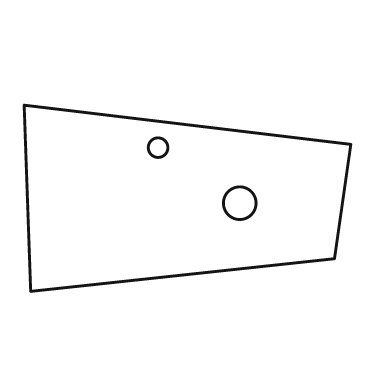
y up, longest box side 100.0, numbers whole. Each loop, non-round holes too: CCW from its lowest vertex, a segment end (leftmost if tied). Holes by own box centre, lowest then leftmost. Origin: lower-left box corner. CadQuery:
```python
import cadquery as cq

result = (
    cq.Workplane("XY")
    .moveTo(2.0, 0.0)
    .lineTo(95.0, 10.0)
    .lineTo(100.0, 45.0)
    .lineTo(0.0, 57.0)
    .close()
    .moveTo(66.0, 27.0)
    .circle(5.0)
    .moveTo(41.0, 44.0)
    .circle(3.0)
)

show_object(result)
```